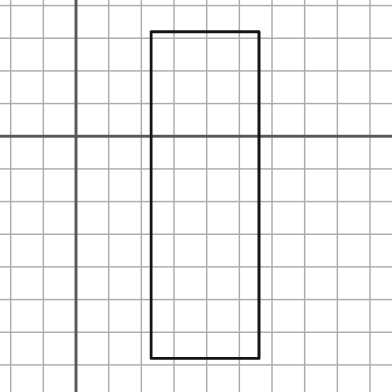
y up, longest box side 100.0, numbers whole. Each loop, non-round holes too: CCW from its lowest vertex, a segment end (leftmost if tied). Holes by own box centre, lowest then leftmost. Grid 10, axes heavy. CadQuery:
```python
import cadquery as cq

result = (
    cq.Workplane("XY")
    .moveTo(23.0, -68.0)
    .lineTo(56.0, -68.0)
    .lineTo(56.0, 32.0)
    .lineTo(23.0, 32.0)
    .close()
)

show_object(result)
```